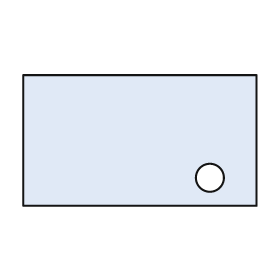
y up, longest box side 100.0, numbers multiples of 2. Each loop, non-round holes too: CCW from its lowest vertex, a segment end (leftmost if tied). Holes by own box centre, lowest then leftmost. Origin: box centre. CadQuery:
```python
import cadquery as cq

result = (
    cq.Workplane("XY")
    .moveTo(-50.0, -28.0)
    .lineTo(50.0, -28.0)
    .lineTo(50.0, 28.0)
    .lineTo(-50.0, 28.0)
    .close()
    .moveTo(30.0, -16.0)
    .circle(6.0)
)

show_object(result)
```